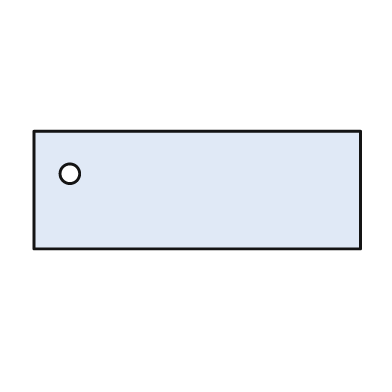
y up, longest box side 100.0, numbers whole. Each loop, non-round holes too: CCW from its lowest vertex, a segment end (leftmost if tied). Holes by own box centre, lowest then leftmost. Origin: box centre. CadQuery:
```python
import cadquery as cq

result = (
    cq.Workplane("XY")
    .moveTo(-50.0, -18.0)
    .lineTo(50.0, -18.0)
    .lineTo(50.0, 18.0)
    .lineTo(-50.0, 18.0)
    .close()
    .moveTo(-39.0, 5.0)
    .circle(3.0)
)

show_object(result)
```